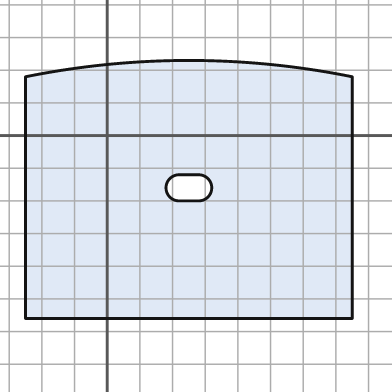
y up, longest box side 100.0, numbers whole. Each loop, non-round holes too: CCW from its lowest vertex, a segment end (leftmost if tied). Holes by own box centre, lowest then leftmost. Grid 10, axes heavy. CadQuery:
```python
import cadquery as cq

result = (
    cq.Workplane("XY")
    .moveTo(-25.0, -56.0)
    .lineTo(75.0, -56.0)
    .lineTo(75.0, 18.0)
    .threePointArc((25.0, 23.0), (-25.0, 18.0))
    .close()
    .moveTo(22.0, -20.0)
    .lineTo(28.0, -20.0)
    .threePointArc((32.0, -16.0), (28.0, -12.0))
    .lineTo(22.0, -12.0)
    .threePointArc((18.0, -16.0), (22.0, -20.0))
    .close()
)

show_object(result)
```